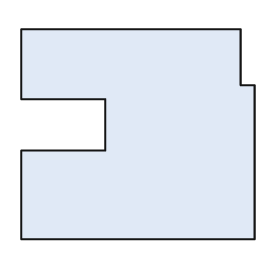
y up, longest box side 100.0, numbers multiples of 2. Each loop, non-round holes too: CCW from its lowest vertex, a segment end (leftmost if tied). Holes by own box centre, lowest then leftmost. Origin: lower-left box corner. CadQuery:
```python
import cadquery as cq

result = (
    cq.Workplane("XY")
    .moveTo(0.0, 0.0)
    .lineTo(100.0, 0.0)
    .lineTo(100.0, 66.0)
    .lineTo(94.0, 66.0)
    .lineTo(94.0, 90.0)
    .lineTo(0.0, 90.0)
    .lineTo(0.0, 60.0)
    .lineTo(36.0, 60.0)
    .lineTo(36.0, 38.0)
    .lineTo(0.0, 38.0)
    .close()
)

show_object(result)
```